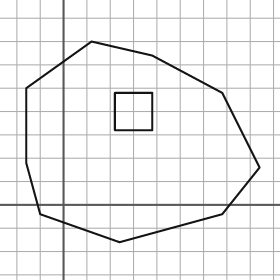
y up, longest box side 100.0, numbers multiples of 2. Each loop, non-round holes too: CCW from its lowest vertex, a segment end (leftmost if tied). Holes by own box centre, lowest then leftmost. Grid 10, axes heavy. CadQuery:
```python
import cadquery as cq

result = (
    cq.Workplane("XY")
    .moveTo(24.0, -16.0)
    .lineTo(68.0, -4.0)
    .lineTo(84.0, 16.0)
    .lineTo(68.0, 48.0)
    .lineTo(38.0, 64.0)
    .lineTo(12.0, 70.0)
    .lineTo(-16.0, 50.0)
    .lineTo(-16.0, 18.0)
    .lineTo(-10.0, -4.0)
    .close()
    .moveTo(22.0, 32.0)
    .lineTo(38.0, 32.0)
    .lineTo(38.0, 48.0)
    .lineTo(22.0, 48.0)
    .close()
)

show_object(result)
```